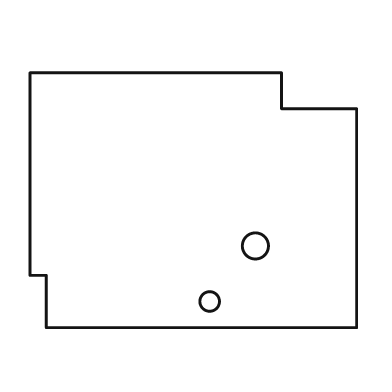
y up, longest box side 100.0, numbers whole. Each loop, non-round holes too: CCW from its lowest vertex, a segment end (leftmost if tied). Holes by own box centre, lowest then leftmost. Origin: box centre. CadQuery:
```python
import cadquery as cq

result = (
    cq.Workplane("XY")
    .moveTo(-45.0, -39.0)
    .lineTo(50.0, -39.0)
    .lineTo(50.0, 28.0)
    .lineTo(27.0, 28.0)
    .lineTo(27.0, 39.0)
    .lineTo(-50.0, 39.0)
    .lineTo(-50.0, -23.0)
    .lineTo(-45.0, -23.0)
    .close()
    .moveTo(5.0, -31.0)
    .circle(3.0)
    .moveTo(19.0, -14.0)
    .circle(4.0)
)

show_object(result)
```